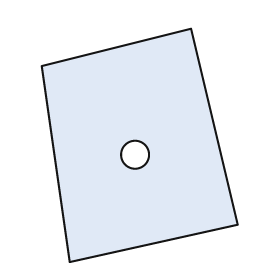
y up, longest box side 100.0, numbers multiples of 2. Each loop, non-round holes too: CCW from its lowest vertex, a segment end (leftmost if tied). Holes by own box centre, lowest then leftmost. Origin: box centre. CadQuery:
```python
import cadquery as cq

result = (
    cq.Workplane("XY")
    .moveTo(-30.0, -50.0)
    .lineTo(42.0, -34.0)
    .lineTo(22.0, 50.0)
    .lineTo(-42.0, 34.0)
    .close()
    .moveTo(-2.0, -4.0)
    .circle(6.0)
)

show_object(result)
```